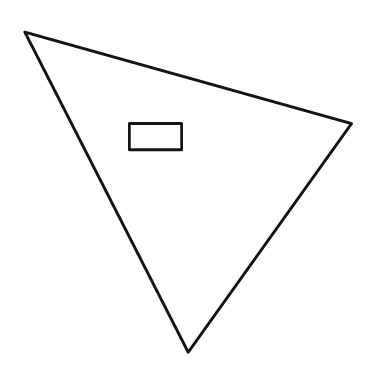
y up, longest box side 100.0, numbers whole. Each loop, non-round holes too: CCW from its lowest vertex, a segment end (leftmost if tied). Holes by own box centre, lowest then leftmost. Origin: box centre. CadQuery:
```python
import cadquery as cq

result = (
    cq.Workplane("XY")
    .moveTo(0.0, -49.0)
    .lineTo(50.0, 21.0)
    .lineTo(-50.0, 49.0)
    .close()
    .moveTo(-18.0, 13.0)
    .lineTo(-2.0, 13.0)
    .lineTo(-2.0, 21.0)
    .lineTo(-18.0, 21.0)
    .close()
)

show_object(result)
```